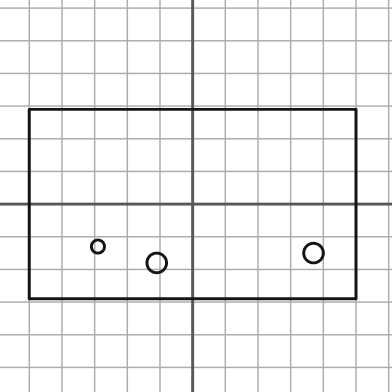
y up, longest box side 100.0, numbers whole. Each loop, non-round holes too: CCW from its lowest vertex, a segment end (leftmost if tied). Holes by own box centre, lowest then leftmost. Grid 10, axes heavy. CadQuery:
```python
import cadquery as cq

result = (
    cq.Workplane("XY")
    .moveTo(-50.0, -29.0)
    .lineTo(50.0, -29.0)
    .lineTo(50.0, 29.0)
    .lineTo(-50.0, 29.0)
    .close()
    .moveTo(-11.0, -18.0)
    .circle(3.0)
    .moveTo(37.0, -15.0)
    .circle(3.0)
    .moveTo(-29.0, -13.0)
    .circle(2.0)
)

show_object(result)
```